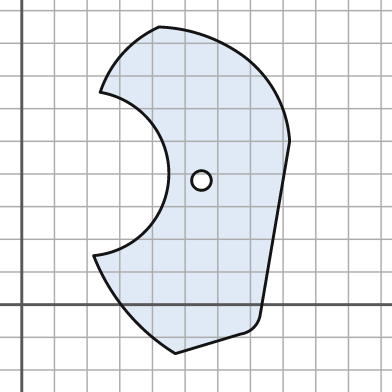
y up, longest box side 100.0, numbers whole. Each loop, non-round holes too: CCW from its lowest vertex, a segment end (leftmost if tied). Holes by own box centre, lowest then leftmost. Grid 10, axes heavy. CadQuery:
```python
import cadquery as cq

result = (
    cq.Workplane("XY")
    .moveTo(47.0, -15.0)
    .lineTo(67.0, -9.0)
    .threePointArc((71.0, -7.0), (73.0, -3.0))
    .lineTo(82.0, 50.0)
    .threePointArc((77.0, 66.0), (65.0, 78.0))
    .threePointArc((54.0, 83.0), (42.0, 85.0))
    .threePointArc((31.0, 77.0), (24.0, 65.0))
    .threePointArc((45.0, 39.0), (22.0, 15.0))
    .threePointArc((32.0, -2.0), (47.0, -15.0))
    .close()
    .moveTo(55.0, 38.0)
    .circle(3.0)
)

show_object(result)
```